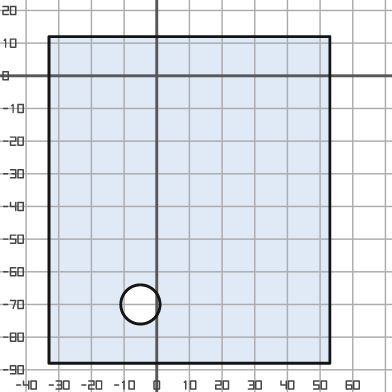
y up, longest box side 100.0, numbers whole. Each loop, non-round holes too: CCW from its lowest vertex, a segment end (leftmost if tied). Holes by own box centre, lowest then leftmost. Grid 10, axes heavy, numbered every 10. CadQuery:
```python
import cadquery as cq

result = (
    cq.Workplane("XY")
    .moveTo(-33.0, -88.0)
    .lineTo(53.0, -88.0)
    .lineTo(53.0, 12.0)
    .lineTo(-33.0, 12.0)
    .close()
    .moveTo(-5.0, -70.0)
    .circle(6.0)
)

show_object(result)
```